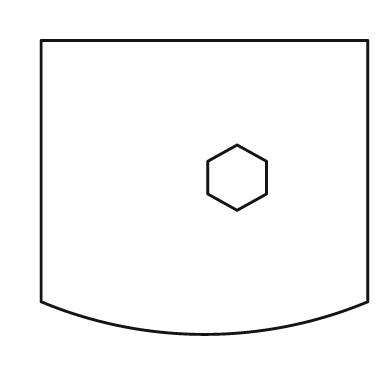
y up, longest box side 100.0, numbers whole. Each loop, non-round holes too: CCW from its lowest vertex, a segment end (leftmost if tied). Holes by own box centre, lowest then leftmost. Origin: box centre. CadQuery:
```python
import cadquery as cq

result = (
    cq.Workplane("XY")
    .moveTo(-50.0, -35.0)
    .threePointArc((0.0, -45.0), (50.0, -35.0))
    .lineTo(50.0, 45.0)
    .lineTo(-50.0, 45.0)
    .close()
    .moveTo(10.0, -7.0)
    .lineTo(19.0, -2.0)
    .lineTo(19.0, 8.0)
    .lineTo(10.0, 13.0)
    .lineTo(1.0, 8.0)
    .lineTo(1.0, -2.0)
    .close()
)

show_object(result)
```